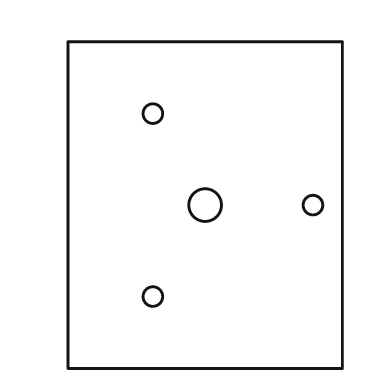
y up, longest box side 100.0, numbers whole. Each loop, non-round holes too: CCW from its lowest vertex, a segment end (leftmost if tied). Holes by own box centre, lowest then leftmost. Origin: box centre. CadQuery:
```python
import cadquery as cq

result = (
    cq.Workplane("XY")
    .moveTo(-42.0, -50.0)
    .lineTo(42.0, -50.0)
    .lineTo(42.0, 50.0)
    .lineTo(-42.0, 50.0)
    .close()
    .moveTo(-16.0, -28.0)
    .circle(3.0)
    .moveTo(0.0, 0.0)
    .circle(5.0)
    .moveTo(33.0, 0.0)
    .circle(3.0)
    .moveTo(-16.0, 28.0)
    .circle(3.0)
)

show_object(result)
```